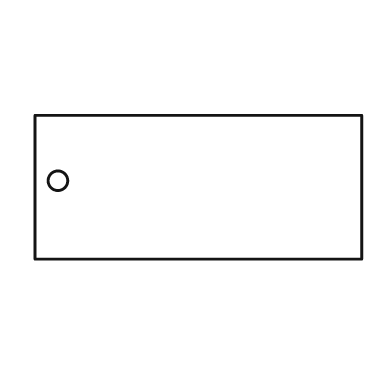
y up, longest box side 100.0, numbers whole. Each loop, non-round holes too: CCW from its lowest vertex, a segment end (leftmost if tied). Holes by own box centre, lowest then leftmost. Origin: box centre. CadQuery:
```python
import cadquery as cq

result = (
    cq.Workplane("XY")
    .moveTo(-50.0, -22.0)
    .lineTo(50.0, -22.0)
    .lineTo(50.0, 22.0)
    .lineTo(-50.0, 22.0)
    .close()
    .moveTo(-43.0, 2.0)
    .circle(3.0)
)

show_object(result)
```